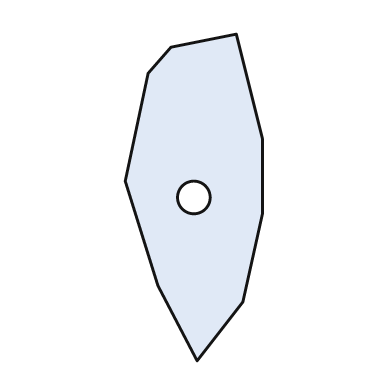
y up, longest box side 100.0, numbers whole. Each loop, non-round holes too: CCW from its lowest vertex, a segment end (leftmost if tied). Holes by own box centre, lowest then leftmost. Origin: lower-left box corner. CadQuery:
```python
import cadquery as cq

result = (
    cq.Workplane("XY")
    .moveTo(22.0, 0.0)
    .lineTo(36.0, 18.0)
    .lineTo(42.0, 45.0)
    .lineTo(42.0, 68.0)
    .lineTo(34.0, 100.0)
    .lineTo(14.0, 96.0)
    .lineTo(7.0, 88.0)
    .lineTo(0.0, 55.0)
    .lineTo(10.0, 23.0)
    .close()
    .moveTo(21.0, 50.0)
    .circle(5.0)
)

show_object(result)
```